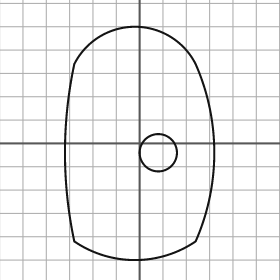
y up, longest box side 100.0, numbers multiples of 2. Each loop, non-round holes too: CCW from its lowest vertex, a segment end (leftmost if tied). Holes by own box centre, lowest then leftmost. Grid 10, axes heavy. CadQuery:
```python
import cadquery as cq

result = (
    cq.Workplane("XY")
    .moveTo(-28.0, -42.0)
    .threePointArc((-2.0, -50.0), (24.0, -42.0))
    .threePointArc((32.0, -4.0), (24.0, 34.0))
    .threePointArc((-2.0, 50.0), (-28.0, 34.0))
    .threePointArc((-32.0, -4.0), (-28.0, -42.0))
    .close()
    .moveTo(8.0, -4.0)
    .circle(8.0)
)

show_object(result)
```